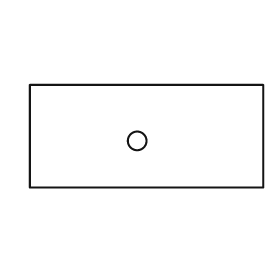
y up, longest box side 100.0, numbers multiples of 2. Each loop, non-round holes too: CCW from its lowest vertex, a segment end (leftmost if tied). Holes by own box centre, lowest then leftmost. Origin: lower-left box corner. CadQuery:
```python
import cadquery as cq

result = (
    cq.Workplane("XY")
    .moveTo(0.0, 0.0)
    .lineTo(100.0, 0.0)
    .lineTo(100.0, 44.0)
    .lineTo(0.0, 44.0)
    .close()
    .moveTo(46.0, 20.0)
    .circle(4.0)
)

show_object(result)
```